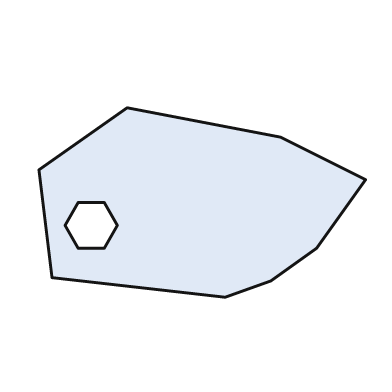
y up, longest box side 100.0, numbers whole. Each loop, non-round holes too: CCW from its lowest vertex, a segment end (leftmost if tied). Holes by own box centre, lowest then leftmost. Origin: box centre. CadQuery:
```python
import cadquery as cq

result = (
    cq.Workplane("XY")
    .moveTo(7.0, -29.0)
    .lineTo(21.0, -24.0)
    .lineTo(35.0, -14.0)
    .lineTo(50.0, 7.0)
    .lineTo(24.0, 20.0)
    .lineTo(-23.0, 29.0)
    .lineTo(-50.0, 10.0)
    .lineTo(-46.0, -23.0)
    .close()
    .moveTo(-38.0, -14.0)
    .lineTo(-30.0, -14.0)
    .lineTo(-26.0, -7.0)
    .lineTo(-30.0, 0.0)
    .lineTo(-38.0, 0.0)
    .lineTo(-42.0, -7.0)
    .close()
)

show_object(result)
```